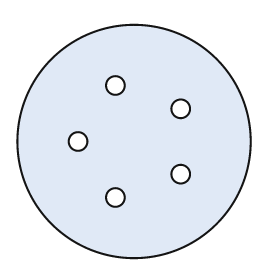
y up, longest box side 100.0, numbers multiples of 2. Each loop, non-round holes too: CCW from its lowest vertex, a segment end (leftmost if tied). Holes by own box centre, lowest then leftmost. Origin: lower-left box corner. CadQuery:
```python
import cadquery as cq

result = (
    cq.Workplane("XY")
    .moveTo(50.0, 50.0)
    .circle(50.0)
    .moveTo(42.0, 26.0)
    .circle(4.0)
    .moveTo(70.0, 36.0)
    .circle(4.0)
    .moveTo(26.0, 50.0)
    .circle(4.0)
    .moveTo(70.0, 64.0)
    .circle(4.0)
    .moveTo(42.0, 74.0)
    .circle(4.0)
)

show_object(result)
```